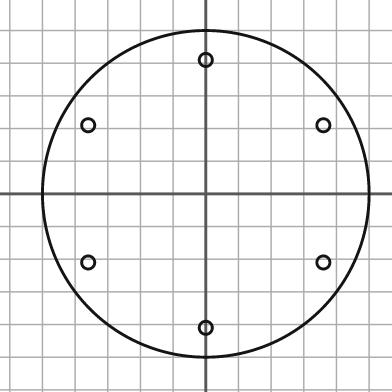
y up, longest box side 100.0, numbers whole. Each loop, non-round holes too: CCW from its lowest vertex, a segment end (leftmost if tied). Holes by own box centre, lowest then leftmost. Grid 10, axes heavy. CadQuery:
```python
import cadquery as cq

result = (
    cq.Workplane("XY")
    .moveTo(0.0, 0.0)
    .circle(50.0)
    .moveTo(0.0, -41.0)
    .circle(2.0)
    .moveTo(-36.0, -21.0)
    .circle(2.0)
    .moveTo(36.0, -21.0)
    .circle(2.0)
    .moveTo(-36.0, 21.0)
    .circle(2.0)
    .moveTo(36.0, 21.0)
    .circle(2.0)
    .moveTo(0.0, 41.0)
    .circle(2.0)
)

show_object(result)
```